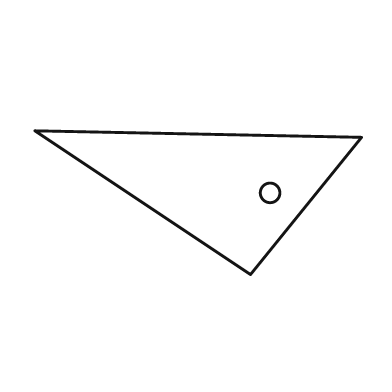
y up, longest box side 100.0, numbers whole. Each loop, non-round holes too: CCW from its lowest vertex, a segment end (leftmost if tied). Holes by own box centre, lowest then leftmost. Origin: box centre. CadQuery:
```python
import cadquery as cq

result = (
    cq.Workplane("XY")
    .moveTo(16.0, -22.0)
    .lineTo(50.0, 20.0)
    .lineTo(-50.0, 22.0)
    .close()
    .moveTo(22.0, 3.0)
    .circle(3.0)
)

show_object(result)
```